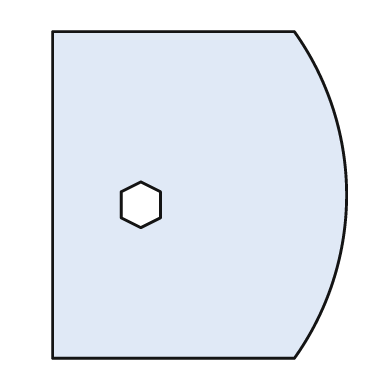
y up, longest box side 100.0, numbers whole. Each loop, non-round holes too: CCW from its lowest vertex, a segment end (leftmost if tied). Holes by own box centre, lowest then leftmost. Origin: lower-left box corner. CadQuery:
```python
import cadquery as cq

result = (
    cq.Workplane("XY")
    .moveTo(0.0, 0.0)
    .lineTo(74.0, 0.0)
    .threePointArc((90.0, 50.0), (74.0, 100.0))
    .lineTo(0.0, 100.0)
    .close()
    .moveTo(27.0, 40.0)
    .lineTo(33.0, 43.0)
    .lineTo(33.0, 51.0)
    .lineTo(27.0, 54.0)
    .lineTo(21.0, 51.0)
    .lineTo(21.0, 43.0)
    .close()
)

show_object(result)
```